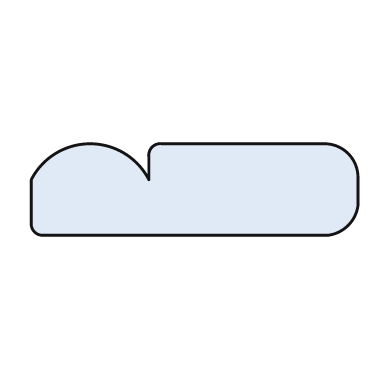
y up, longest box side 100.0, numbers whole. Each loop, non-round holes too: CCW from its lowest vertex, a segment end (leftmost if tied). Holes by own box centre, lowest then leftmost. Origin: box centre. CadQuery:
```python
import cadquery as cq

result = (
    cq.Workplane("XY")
    .moveTo(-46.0, -14.0)
    .lineTo(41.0, -14.0)
    .threePointArc((47.0, -11.0), (50.0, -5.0))
    .lineTo(50.0, 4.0)
    .threePointArc((47.0, 11.0), (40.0, 14.0))
    .lineTo(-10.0, 14.0)
    .threePointArc((-13.0, 13.0), (-14.0, 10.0))
    .lineTo(-14.0, 3.0)
    .threePointArc((-32.0, 14.0), (-50.0, 3.0))
    .lineTo(-50.0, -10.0)
    .threePointArc((-49.0, -13.0), (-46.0, -14.0))
    .close()
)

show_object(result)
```